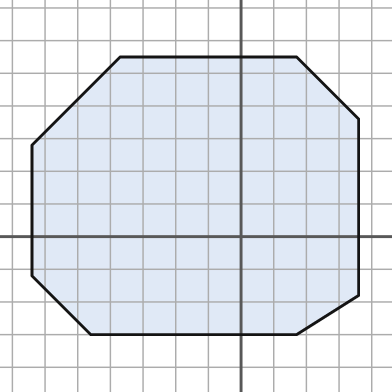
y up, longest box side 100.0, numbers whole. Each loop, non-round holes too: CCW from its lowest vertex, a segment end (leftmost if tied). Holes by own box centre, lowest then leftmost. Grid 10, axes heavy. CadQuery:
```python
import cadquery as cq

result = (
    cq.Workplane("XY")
    .moveTo(-46.0, -30.0)
    .lineTo(17.0, -30.0)
    .lineTo(36.0, -18.0)
    .lineTo(36.0, 36.0)
    .lineTo(17.0, 55.0)
    .lineTo(-37.0, 55.0)
    .lineTo(-64.0, 28.0)
    .lineTo(-64.0, -12.0)
    .close()
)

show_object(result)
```